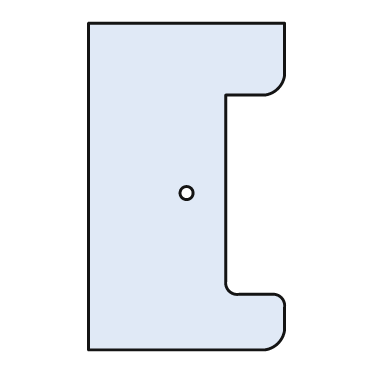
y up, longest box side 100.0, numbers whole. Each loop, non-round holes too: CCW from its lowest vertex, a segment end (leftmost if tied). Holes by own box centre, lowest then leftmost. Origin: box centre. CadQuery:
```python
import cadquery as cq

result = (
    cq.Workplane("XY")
    .moveTo(-30.0, -50.0)
    .lineTo(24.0, -50.0)
    .threePointArc((28.0, -48.0), (30.0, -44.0))
    .lineTo(30.0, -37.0)
    .threePointArc((29.0, -34.0), (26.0, -33.0))
    .lineTo(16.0, -33.0)
    .threePointArc((13.0, -32.0), (12.0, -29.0))
    .lineTo(12.0, 28.0)
    .lineTo(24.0, 28.0)
    .threePointArc((28.0, 30.0), (30.0, 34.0))
    .lineTo(30.0, 50.0)
    .lineTo(-30.0, 50.0)
    .close()
    .moveTo(0.0, -2.0)
    .circle(2.0)
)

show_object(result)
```